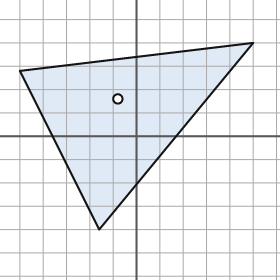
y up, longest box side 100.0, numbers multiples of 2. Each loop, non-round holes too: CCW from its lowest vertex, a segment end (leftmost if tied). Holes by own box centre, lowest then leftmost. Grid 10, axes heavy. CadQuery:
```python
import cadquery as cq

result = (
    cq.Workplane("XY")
    .moveTo(-16.0, -40.0)
    .lineTo(50.0, 40.0)
    .lineTo(-50.0, 28.0)
    .close()
    .moveTo(-8.0, 16.0)
    .circle(2.0)
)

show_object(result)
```